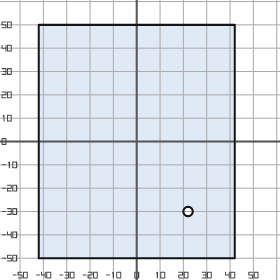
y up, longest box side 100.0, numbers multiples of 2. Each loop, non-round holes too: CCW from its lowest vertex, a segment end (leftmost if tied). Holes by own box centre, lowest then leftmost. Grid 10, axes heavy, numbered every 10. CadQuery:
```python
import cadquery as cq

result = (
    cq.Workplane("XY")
    .moveTo(-42.0, -50.0)
    .lineTo(42.0, -50.0)
    .lineTo(42.0, 50.0)
    .lineTo(-42.0, 50.0)
    .close()
    .moveTo(22.0, -30.0)
    .circle(2.0)
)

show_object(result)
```